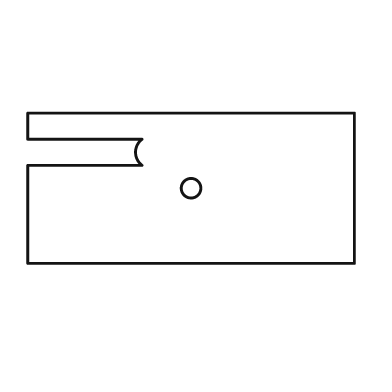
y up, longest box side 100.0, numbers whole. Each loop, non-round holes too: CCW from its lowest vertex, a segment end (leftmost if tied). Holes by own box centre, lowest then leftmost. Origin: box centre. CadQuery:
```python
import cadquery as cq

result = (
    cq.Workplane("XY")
    .moveTo(-50.0, -23.0)
    .lineTo(50.0, -23.0)
    .lineTo(50.0, 23.0)
    .lineTo(-50.0, 23.0)
    .lineTo(-50.0, 15.0)
    .lineTo(-15.0, 15.0)
    .threePointArc((-17.0, 11.0), (-15.0, 7.0))
    .lineTo(-50.0, 7.0)
    .close()
    .moveTo(0.0, 0.0)
    .circle(3.0)
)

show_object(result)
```